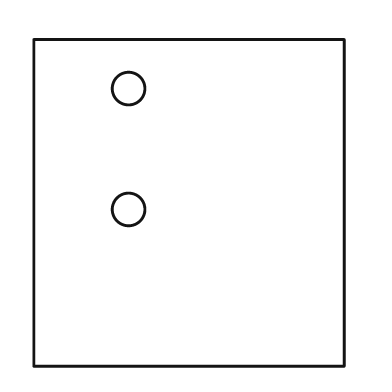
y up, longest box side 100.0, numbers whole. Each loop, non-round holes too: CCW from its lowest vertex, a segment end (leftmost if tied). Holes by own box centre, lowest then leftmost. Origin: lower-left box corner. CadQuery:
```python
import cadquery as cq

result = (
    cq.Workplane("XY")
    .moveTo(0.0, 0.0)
    .lineTo(95.0, 0.0)
    .lineTo(95.0, 100.0)
    .lineTo(0.0, 100.0)
    .close()
    .moveTo(29.0, 48.0)
    .circle(5.0)
    .moveTo(29.0, 85.0)
    .circle(5.0)
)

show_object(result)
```